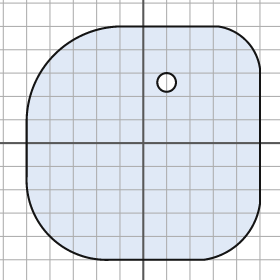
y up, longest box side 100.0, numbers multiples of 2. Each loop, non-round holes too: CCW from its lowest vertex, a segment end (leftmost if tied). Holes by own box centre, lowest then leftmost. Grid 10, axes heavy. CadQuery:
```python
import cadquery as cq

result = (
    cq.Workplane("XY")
    .moveTo(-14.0, -50.0)
    .lineTo(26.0, -50.0)
    .threePointArc((42.0, -42.0), (50.0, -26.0))
    .lineTo(50.0, 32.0)
    .threePointArc((44.0, 44.0), (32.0, 50.0))
    .lineTo(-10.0, 50.0)
    .threePointArc((-38.0, 38.0), (-50.0, 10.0))
    .lineTo(-50.0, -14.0)
    .threePointArc((-40.0, -40.0), (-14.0, -50.0))
    .close()
    .moveTo(10.0, 26.0)
    .circle(4.0)
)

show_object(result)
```